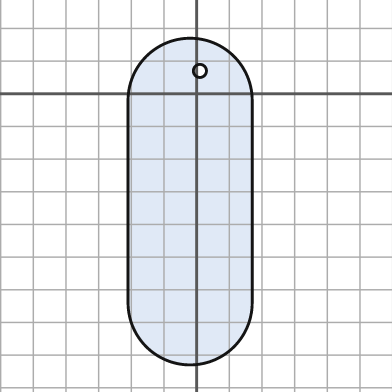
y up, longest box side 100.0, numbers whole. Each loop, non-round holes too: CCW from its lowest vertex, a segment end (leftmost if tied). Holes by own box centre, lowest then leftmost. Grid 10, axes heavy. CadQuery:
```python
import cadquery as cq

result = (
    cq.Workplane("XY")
    .moveTo(-21.0, -64.0)
    .threePointArc((-2.0, -83.0), (17.0, -64.0))
    .lineTo(17.0, -2.0)
    .threePointArc((-2.0, 17.0), (-21.0, -2.0))
    .close()
    .moveTo(1.0, 7.0)
    .circle(2.0)
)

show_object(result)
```